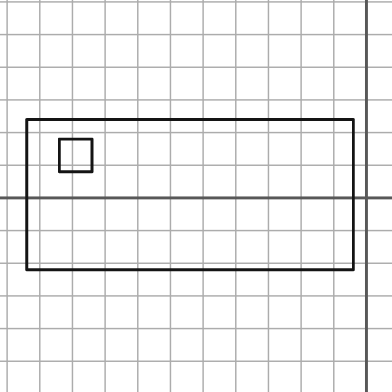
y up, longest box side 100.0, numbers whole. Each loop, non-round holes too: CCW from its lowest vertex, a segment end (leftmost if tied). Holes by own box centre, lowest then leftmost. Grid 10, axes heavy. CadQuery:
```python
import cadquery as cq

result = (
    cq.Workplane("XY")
    .moveTo(-104.0, -22.0)
    .lineTo(-4.0, -22.0)
    .lineTo(-4.0, 24.0)
    .lineTo(-104.0, 24.0)
    .close()
    .moveTo(-94.0, 8.0)
    .lineTo(-84.0, 8.0)
    .lineTo(-84.0, 18.0)
    .lineTo(-94.0, 18.0)
    .close()
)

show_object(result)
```